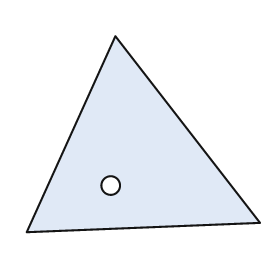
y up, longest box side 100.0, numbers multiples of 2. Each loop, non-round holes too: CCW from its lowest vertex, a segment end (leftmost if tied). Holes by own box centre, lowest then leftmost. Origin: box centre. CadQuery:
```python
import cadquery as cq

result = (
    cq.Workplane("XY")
    .moveTo(-50.0, -42.0)
    .lineTo(50.0, -38.0)
    .lineTo(-12.0, 42.0)
    .close()
    .moveTo(-14.0, -22.0)
    .circle(4.0)
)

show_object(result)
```